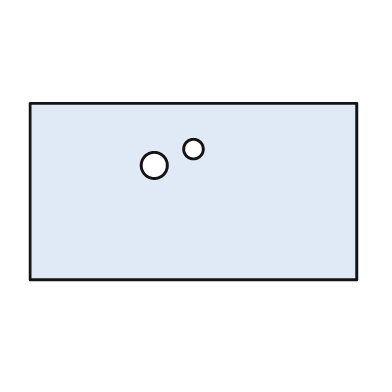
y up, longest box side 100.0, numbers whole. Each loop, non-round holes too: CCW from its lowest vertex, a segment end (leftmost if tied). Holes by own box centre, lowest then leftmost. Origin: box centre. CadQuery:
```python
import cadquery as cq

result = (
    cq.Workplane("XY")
    .moveTo(-50.0, -27.0)
    .lineTo(50.0, -27.0)
    .lineTo(50.0, 27.0)
    .lineTo(-50.0, 27.0)
    .close()
    .moveTo(-12.0, 8.0)
    .circle(4.0)
    .moveTo(0.0, 13.0)
    .circle(3.0)
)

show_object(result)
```